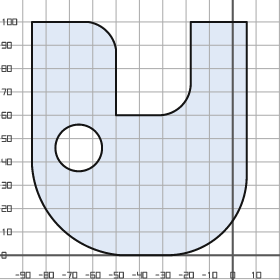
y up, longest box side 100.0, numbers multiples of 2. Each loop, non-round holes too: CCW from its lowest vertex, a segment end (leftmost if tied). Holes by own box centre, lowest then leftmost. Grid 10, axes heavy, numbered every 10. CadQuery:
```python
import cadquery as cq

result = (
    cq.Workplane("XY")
    .moveTo(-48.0, 0.0)
    .lineTo(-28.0, 0.0)
    .threePointArc((-4.0, 10.0), (6.0, 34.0))
    .lineTo(6.0, 100.0)
    .lineTo(-18.0, 100.0)
    .lineTo(-18.0, 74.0)
    .threePointArc((-22.0, 64.0), (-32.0, 60.0))
    .lineTo(-50.0, 60.0)
    .lineTo(-50.0, 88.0)
    .threePointArc((-54.0, 96.0), (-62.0, 100.0))
    .lineTo(-86.0, 100.0)
    .lineTo(-86.0, 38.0)
    .threePointArc((-74.0, 12.0), (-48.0, 0.0))
    .close()
    .moveTo(-66.0, 46.0)
    .circle(10.0)
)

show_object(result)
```